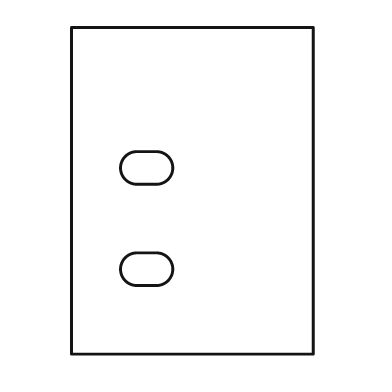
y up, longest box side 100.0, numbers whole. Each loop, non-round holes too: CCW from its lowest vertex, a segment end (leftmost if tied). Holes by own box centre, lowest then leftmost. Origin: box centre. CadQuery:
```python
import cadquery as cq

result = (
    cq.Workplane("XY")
    .moveTo(-37.0, -50.0)
    .lineTo(37.0, -50.0)
    .lineTo(37.0, 50.0)
    .lineTo(-37.0, 50.0)
    .close()
    .moveTo(-17.0, -29.0)
    .lineTo(-11.0, -29.0)
    .threePointArc((-6.0, -24.0), (-11.0, -19.0))
    .lineTo(-17.0, -19.0)
    .threePointArc((-22.0, -24.0), (-17.0, -29.0))
    .close()
    .moveTo(-17.0, 2.0)
    .lineTo(-11.0, 2.0)
    .threePointArc((-6.0, 7.0), (-11.0, 12.0))
    .lineTo(-17.0, 12.0)
    .threePointArc((-22.0, 7.0), (-17.0, 2.0))
    .close()
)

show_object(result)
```